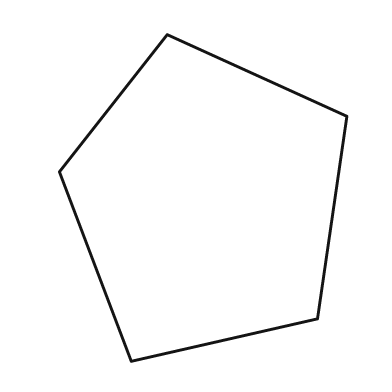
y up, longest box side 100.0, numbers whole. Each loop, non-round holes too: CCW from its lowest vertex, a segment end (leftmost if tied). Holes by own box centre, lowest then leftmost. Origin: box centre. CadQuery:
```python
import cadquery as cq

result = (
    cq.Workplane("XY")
    .moveTo(-22.0, -50.0)
    .lineTo(35.0, -37.0)
    .lineTo(44.0, 25.0)
    .lineTo(-11.0, 50.0)
    .lineTo(-44.0, 8.0)
    .close()
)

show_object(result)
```